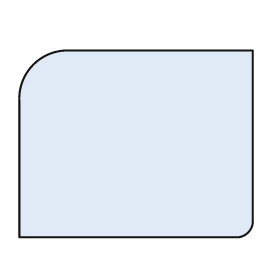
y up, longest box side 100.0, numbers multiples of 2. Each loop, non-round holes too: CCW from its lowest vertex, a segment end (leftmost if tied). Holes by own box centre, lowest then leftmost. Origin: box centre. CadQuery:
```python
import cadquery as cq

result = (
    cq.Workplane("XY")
    .moveTo(-50.0, -40.0)
    .lineTo(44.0, -40.0)
    .threePointArc((48.0, -38.0), (50.0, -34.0))
    .lineTo(50.0, 40.0)
    .lineTo(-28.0, 40.0)
    .threePointArc((-44.0, 34.0), (-50.0, 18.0))
    .close()
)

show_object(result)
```